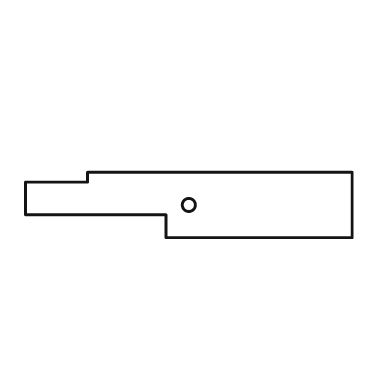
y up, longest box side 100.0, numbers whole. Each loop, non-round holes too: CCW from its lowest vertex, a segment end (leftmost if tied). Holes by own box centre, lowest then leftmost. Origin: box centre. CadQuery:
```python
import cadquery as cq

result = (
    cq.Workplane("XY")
    .moveTo(-7.0, -10.0)
    .lineTo(50.0, -10.0)
    .lineTo(50.0, 10.0)
    .lineTo(-31.0, 10.0)
    .lineTo(-31.0, 7.0)
    .lineTo(-50.0, 7.0)
    .lineTo(-50.0, -3.0)
    .lineTo(-7.0, -3.0)
    .close()
    .moveTo(0.0, 0.0)
    .circle(2.0)
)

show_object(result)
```